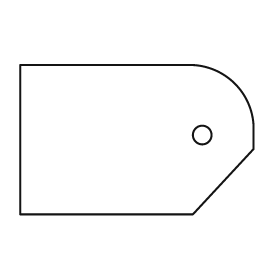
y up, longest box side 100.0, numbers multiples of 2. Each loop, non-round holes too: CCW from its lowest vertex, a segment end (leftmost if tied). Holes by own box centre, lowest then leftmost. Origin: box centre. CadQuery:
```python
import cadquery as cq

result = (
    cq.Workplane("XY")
    .moveTo(-50.0, -32.0)
    .lineTo(24.0, -32.0)
    .lineTo(50.0, -4.0)
    .lineTo(50.0, 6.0)
    .threePointArc((42.0, 24.0), (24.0, 32.0))
    .lineTo(-50.0, 32.0)
    .close()
    .moveTo(28.0, 2.0)
    .circle(4.0)
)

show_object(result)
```